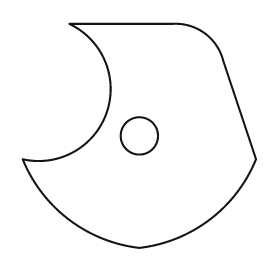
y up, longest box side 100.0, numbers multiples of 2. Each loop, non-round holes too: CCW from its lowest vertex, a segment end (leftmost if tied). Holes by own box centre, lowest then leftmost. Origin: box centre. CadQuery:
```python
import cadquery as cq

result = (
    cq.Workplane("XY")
    .moveTo(0.0, -48.0)
    .threePointArc((30.0, -36.0), (50.0, -10.0))
    .lineTo(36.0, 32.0)
    .threePointArc((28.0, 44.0), (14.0, 48.0))
    .lineTo(-30.0, 48.0)
    .threePointArc((-14.0, 10.0), (-50.0, -10.0))
    .threePointArc((-30.0, -36.0), (0.0, -48.0))
    .close()
    .moveTo(0.0, 0.0)
    .circle(8.0)
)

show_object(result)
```